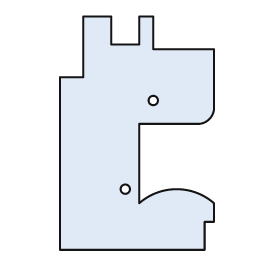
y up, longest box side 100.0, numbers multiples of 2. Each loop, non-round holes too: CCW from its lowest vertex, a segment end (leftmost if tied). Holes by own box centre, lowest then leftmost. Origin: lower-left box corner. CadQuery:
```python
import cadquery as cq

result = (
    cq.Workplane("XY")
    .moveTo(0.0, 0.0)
    .lineTo(62.0, 0.0)
    .lineTo(62.0, 12.0)
    .lineTo(66.0, 12.0)
    .lineTo(66.0, 20.0)
    .threePointArc((50.0, 26.0), (34.0, 20.0))
    .lineTo(34.0, 54.0)
    .lineTo(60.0, 54.0)
    .threePointArc((64.0, 56.0), (66.0, 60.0))
    .lineTo(66.0, 86.0)
    .lineTo(40.0, 86.0)
    .lineTo(40.0, 100.0)
    .lineTo(34.0, 100.0)
    .lineTo(34.0, 88.0)
    .lineTo(22.0, 88.0)
    .lineTo(22.0, 100.0)
    .lineTo(10.0, 100.0)
    .lineTo(10.0, 74.0)
    .lineTo(0.0, 74.0)
    .close()
    .moveTo(28.0, 26.0)
    .circle(2.0)
    .moveTo(40.0, 64.0)
    .circle(2.0)
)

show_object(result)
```